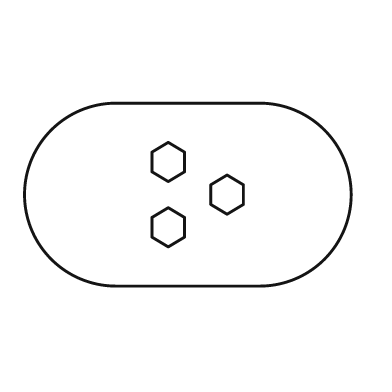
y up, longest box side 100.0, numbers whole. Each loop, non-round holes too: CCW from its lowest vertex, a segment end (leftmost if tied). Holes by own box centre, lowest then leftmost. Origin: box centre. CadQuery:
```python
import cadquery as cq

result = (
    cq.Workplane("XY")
    .moveTo(-22.0, -28.0)
    .lineTo(22.0, -28.0)
    .threePointArc((50.0, 0.0), (22.0, 28.0))
    .lineTo(-22.0, 28.0)
    .threePointArc((-50.0, 0.0), (-22.0, -28.0))
    .close()
    .moveTo(-6.0, -16.0)
    .lineTo(-1.0, -13.0)
    .lineTo(-1.0, -7.0)
    .lineTo(-6.0, -4.0)
    .lineTo(-11.0, -7.0)
    .lineTo(-11.0, -13.0)
    .close()
    .moveTo(12.0, -6.0)
    .lineTo(17.0, -3.0)
    .lineTo(17.0, 3.0)
    .lineTo(12.0, 6.0)
    .lineTo(7.0, 3.0)
    .lineTo(7.0, -3.0)
    .close()
    .moveTo(-6.0, 4.0)
    .lineTo(-1.0, 7.0)
    .lineTo(-1.0, 13.0)
    .lineTo(-6.0, 16.0)
    .lineTo(-11.0, 13.0)
    .lineTo(-11.0, 7.0)
    .close()
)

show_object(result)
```